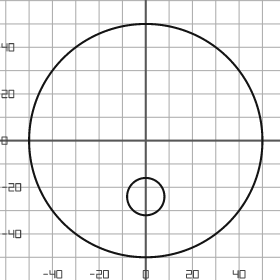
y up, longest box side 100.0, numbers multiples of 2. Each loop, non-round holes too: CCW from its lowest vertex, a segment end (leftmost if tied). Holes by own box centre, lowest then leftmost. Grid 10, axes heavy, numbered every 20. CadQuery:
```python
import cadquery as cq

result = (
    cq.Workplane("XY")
    .moveTo(0.0, 0.0)
    .circle(50.0)
    .moveTo(0.0, -24.0)
    .circle(8.0)
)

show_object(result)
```